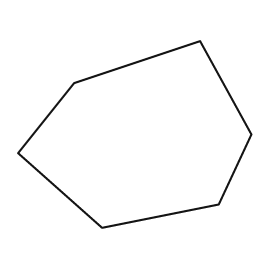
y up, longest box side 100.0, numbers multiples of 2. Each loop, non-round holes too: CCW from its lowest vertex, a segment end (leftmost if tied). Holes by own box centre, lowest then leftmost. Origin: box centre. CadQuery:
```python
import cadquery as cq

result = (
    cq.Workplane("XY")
    .moveTo(-14.0, -40.0)
    .lineTo(36.0, -30.0)
    .lineTo(50.0, 0.0)
    .lineTo(28.0, 40.0)
    .lineTo(-26.0, 22.0)
    .lineTo(-50.0, -8.0)
    .close()
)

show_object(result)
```